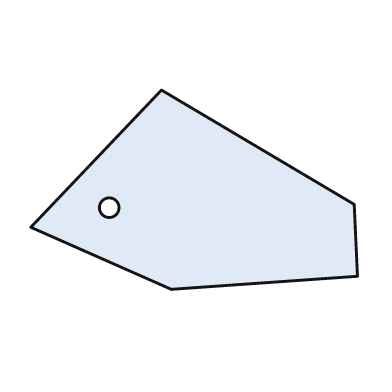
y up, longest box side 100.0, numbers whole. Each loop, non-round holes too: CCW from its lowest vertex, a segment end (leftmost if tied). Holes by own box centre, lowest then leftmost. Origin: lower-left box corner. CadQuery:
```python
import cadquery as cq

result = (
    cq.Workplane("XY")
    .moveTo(43.0, 0.0)
    .lineTo(100.0, 4.0)
    .lineTo(99.0, 26.0)
    .lineTo(40.0, 61.0)
    .lineTo(0.0, 19.0)
    .close()
    .moveTo(24.0, 25.0)
    .circle(3.0)
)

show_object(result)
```